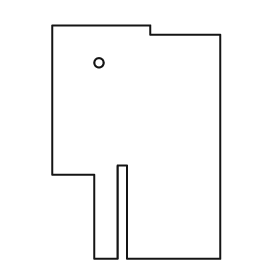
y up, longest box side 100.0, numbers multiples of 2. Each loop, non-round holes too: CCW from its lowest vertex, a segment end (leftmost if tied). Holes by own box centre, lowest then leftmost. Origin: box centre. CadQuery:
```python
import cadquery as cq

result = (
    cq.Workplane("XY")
    .moveTo(-18.0, -50.0)
    .lineTo(-8.0, -50.0)
    .lineTo(-8.0, -10.0)
    .lineTo(-4.0, -10.0)
    .lineTo(-4.0, -50.0)
    .lineTo(36.0, -50.0)
    .lineTo(36.0, 46.0)
    .lineTo(6.0, 46.0)
    .lineTo(6.0, 50.0)
    .lineTo(-36.0, 50.0)
    .lineTo(-36.0, -14.0)
    .lineTo(-18.0, -14.0)
    .close()
    .moveTo(-16.0, 34.0)
    .circle(2.0)
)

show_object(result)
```